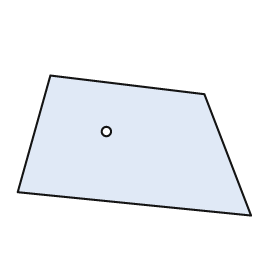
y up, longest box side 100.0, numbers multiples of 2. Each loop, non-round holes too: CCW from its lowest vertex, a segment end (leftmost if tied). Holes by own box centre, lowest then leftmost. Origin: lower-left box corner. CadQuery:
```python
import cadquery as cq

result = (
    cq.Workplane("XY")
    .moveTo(100.0, 0.0)
    .lineTo(80.0, 52.0)
    .lineTo(14.0, 60.0)
    .lineTo(0.0, 10.0)
    .close()
    .moveTo(38.0, 36.0)
    .circle(2.0)
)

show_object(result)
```